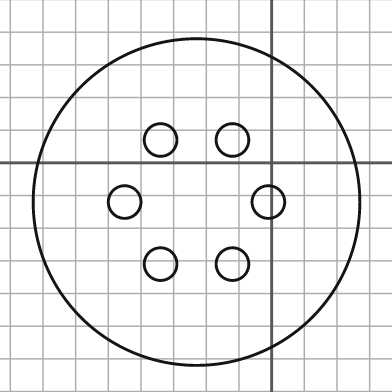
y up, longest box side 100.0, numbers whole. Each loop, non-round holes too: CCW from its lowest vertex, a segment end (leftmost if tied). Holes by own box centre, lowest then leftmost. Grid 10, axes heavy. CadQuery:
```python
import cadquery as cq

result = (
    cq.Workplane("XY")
    .moveTo(-23.0, -12.0)
    .circle(50.0)
    .moveTo(-34.0, -31.0)
    .circle(5.0)
    .moveTo(-12.0, -31.0)
    .circle(5.0)
    .moveTo(-45.0, -12.0)
    .circle(5.0)
    .moveTo(-1.0, -12.0)
    .circle(5.0)
    .moveTo(-34.0, 7.0)
    .circle(5.0)
    .moveTo(-12.0, 7.0)
    .circle(5.0)
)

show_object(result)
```